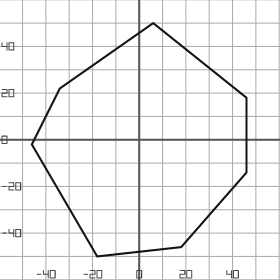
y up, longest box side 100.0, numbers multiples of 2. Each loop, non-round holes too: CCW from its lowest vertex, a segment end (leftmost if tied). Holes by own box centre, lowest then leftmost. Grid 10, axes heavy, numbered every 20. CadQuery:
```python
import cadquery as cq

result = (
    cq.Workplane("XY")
    .moveTo(-18.0, -50.0)
    .lineTo(18.0, -46.0)
    .lineTo(46.0, -14.0)
    .lineTo(46.0, 18.0)
    .lineTo(6.0, 50.0)
    .lineTo(-34.0, 22.0)
    .lineTo(-46.0, -2.0)
    .close()
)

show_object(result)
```